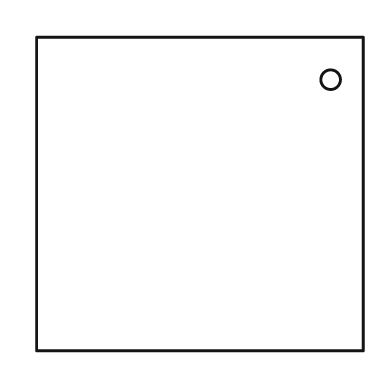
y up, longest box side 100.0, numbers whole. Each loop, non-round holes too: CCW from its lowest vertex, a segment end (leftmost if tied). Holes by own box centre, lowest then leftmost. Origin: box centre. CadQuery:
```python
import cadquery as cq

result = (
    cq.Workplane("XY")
    .moveTo(-50.0, -48.0)
    .lineTo(50.0, -48.0)
    .lineTo(50.0, 48.0)
    .lineTo(-50.0, 48.0)
    .close()
    .moveTo(40.0, 35.0)
    .circle(3.0)
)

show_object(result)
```